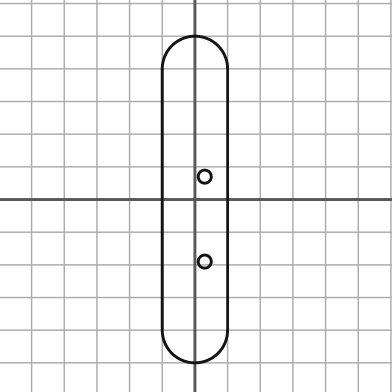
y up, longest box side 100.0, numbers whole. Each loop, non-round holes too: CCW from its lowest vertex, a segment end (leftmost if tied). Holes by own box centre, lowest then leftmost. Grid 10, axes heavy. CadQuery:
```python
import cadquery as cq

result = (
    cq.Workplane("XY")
    .moveTo(-10.0, -40.0)
    .threePointArc((0.0, -50.0), (10.0, -40.0))
    .lineTo(10.0, 40.0)
    .threePointArc((0.0, 50.0), (-10.0, 40.0))
    .close()
    .moveTo(3.0, -19.0)
    .circle(2.0)
    .moveTo(3.0, 7.0)
    .circle(2.0)
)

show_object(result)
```